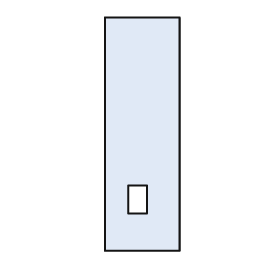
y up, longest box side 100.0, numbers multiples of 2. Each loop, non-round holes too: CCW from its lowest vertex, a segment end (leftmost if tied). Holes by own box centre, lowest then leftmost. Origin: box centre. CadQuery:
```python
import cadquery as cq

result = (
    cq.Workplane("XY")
    .moveTo(-16.0, -50.0)
    .lineTo(16.0, -50.0)
    .lineTo(16.0, 50.0)
    .lineTo(-16.0, 50.0)
    .close()
    .moveTo(-6.0, -34.0)
    .lineTo(2.0, -34.0)
    .lineTo(2.0, -22.0)
    .lineTo(-6.0, -22.0)
    .close()
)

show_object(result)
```